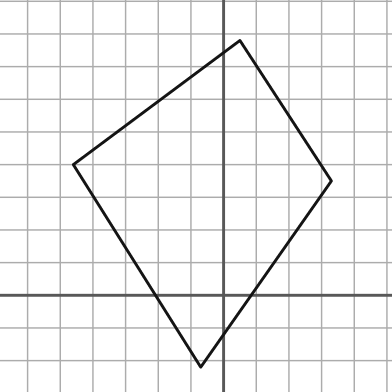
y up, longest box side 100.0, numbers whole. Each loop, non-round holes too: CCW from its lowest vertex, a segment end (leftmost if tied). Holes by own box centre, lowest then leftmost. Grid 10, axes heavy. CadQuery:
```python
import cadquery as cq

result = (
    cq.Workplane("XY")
    .moveTo(-7.0, -22.0)
    .lineTo(33.0, 35.0)
    .lineTo(5.0, 78.0)
    .lineTo(-46.0, 40.0)
    .close()
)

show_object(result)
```